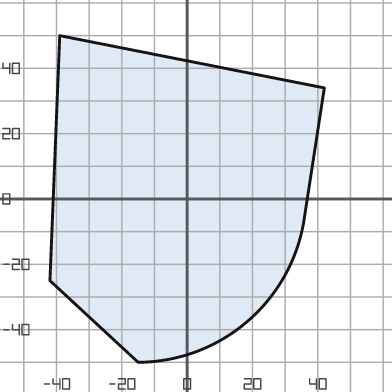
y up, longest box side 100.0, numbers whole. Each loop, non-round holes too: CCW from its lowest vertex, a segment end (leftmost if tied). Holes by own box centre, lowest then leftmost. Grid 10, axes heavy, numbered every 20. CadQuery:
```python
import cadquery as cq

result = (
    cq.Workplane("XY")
    .moveTo(-15.0, -50.0)
    .threePointArc((19.0, -37.0), (36.0, -5.0))
    .lineTo(42.0, 34.0)
    .lineTo(-39.0, 50.0)
    .lineTo(-42.0, -25.0)
    .close()
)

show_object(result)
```